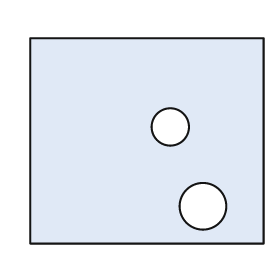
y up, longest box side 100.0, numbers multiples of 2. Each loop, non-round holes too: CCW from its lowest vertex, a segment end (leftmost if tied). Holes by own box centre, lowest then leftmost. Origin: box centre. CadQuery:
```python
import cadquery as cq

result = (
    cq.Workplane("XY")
    .moveTo(-50.0, -44.0)
    .lineTo(50.0, -44.0)
    .lineTo(50.0, 44.0)
    .lineTo(-50.0, 44.0)
    .close()
    .moveTo(24.0, -28.0)
    .circle(10.0)
    .moveTo(10.0, 6.0)
    .circle(8.0)
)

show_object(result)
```